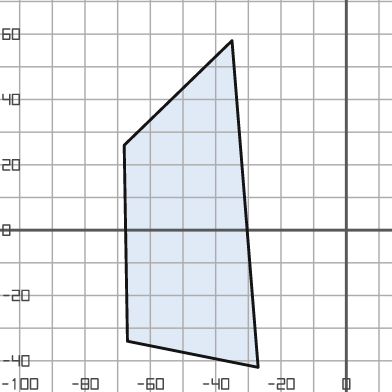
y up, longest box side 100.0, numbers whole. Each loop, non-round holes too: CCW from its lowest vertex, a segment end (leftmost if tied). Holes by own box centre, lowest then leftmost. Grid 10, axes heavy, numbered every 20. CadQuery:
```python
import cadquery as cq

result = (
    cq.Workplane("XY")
    .moveTo(-27.0, -42.0)
    .lineTo(-35.0, 58.0)
    .lineTo(-68.0, 26.0)
    .lineTo(-67.0, -34.0)
    .close()
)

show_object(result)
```